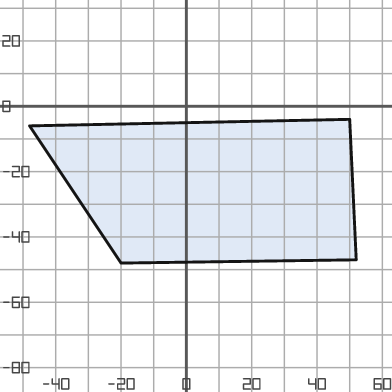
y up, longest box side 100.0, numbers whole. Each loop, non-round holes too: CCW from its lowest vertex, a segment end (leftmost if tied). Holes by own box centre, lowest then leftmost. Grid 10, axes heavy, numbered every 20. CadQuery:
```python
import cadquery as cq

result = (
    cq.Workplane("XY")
    .moveTo(-20.0, -48.0)
    .lineTo(52.0, -47.0)
    .lineTo(50.0, -4.0)
    .lineTo(-48.0, -6.0)
    .close()
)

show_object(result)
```